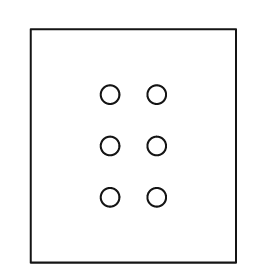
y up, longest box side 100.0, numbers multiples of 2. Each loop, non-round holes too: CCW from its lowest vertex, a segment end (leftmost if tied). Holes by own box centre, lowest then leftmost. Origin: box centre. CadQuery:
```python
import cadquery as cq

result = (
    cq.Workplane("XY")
    .moveTo(-44.0, -50.0)
    .lineTo(44.0, -50.0)
    .lineTo(44.0, 50.0)
    .lineTo(-44.0, 50.0)
    .close()
    .moveTo(-10.0, -22.0)
    .circle(4.0)
    .moveTo(10.0, -22.0)
    .circle(4.0)
    .moveTo(-10.0, 0.0)
    .circle(4.0)
    .moveTo(10.0, 0.0)
    .circle(4.0)
    .moveTo(-10.0, 22.0)
    .circle(4.0)
    .moveTo(10.0, 22.0)
    .circle(4.0)
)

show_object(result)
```